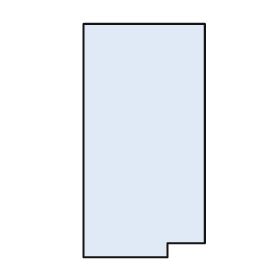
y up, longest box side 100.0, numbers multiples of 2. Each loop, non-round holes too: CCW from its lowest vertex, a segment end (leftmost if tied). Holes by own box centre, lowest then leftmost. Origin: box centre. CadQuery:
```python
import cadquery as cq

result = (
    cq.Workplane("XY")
    .moveTo(-26.0, -50.0)
    .lineTo(10.0, -50.0)
    .lineTo(10.0, -44.0)
    .lineTo(26.0, -44.0)
    .lineTo(26.0, 50.0)
    .lineTo(-26.0, 50.0)
    .close()
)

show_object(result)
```